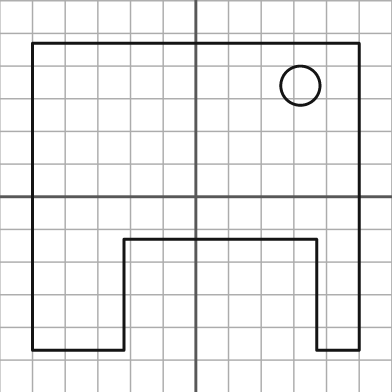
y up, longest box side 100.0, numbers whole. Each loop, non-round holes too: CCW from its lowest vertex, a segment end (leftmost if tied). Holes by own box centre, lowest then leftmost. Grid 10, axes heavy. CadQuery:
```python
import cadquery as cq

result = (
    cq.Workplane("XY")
    .moveTo(-50.0, -47.0)
    .lineTo(-22.0, -47.0)
    .lineTo(-22.0, -13.0)
    .lineTo(37.0, -13.0)
    .lineTo(37.0, -47.0)
    .lineTo(50.0, -47.0)
    .lineTo(50.0, 47.0)
    .lineTo(-50.0, 47.0)
    .close()
    .moveTo(32.0, 34.0)
    .circle(6.0)
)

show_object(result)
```